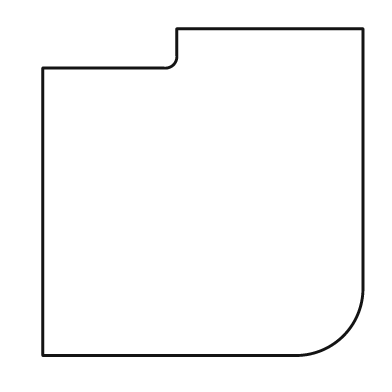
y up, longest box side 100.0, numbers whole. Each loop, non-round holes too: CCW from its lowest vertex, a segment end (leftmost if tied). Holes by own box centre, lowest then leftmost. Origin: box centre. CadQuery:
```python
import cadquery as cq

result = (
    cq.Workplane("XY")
    .moveTo(-49.0, -50.0)
    .lineTo(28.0, -50.0)
    .threePointArc((43.0, -44.0), (49.0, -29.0))
    .lineTo(49.0, 50.0)
    .lineTo(-8.0, 50.0)
    .lineTo(-8.0, 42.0)
    .threePointArc((-9.0, 39.0), (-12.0, 38.0))
    .lineTo(-49.0, 38.0)
    .close()
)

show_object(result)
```